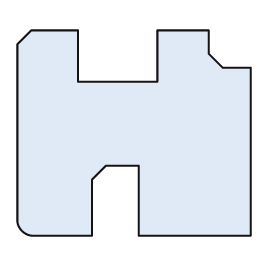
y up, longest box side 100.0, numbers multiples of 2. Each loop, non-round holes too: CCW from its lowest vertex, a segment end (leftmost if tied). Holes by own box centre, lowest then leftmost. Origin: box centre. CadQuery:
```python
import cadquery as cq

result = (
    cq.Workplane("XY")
    .moveTo(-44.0, -44.0)
    .lineTo(-18.0, -44.0)
    .lineTo(-18.0, -20.0)
    .lineTo(-12.0, -14.0)
    .lineTo(2.0, -14.0)
    .lineTo(2.0, -44.0)
    .lineTo(50.0, -44.0)
    .lineTo(50.0, 28.0)
    .lineTo(38.0, 28.0)
    .lineTo(32.0, 34.0)
    .lineTo(32.0, 44.0)
    .lineTo(10.0, 44.0)
    .lineTo(10.0, 22.0)
    .lineTo(-24.0, 22.0)
    .lineTo(-24.0, 44.0)
    .lineTo(-44.0, 44.0)
    .lineTo(-50.0, 38.0)
    .lineTo(-50.0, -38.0)
    .threePointArc((-48.0, -42.0), (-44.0, -44.0))
    .close()
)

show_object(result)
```